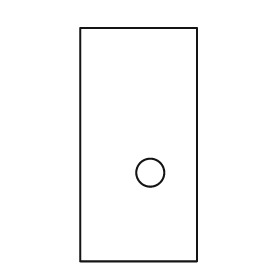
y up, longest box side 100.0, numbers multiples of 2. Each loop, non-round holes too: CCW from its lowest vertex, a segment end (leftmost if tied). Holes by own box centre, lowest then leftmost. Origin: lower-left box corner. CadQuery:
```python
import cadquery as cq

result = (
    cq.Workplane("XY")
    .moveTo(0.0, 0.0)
    .lineTo(50.0, 0.0)
    .lineTo(50.0, 100.0)
    .lineTo(0.0, 100.0)
    .close()
    .moveTo(30.0, 38.0)
    .circle(6.0)
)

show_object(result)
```